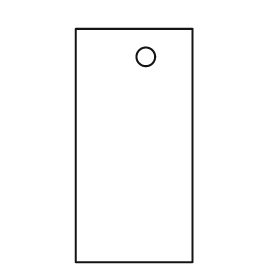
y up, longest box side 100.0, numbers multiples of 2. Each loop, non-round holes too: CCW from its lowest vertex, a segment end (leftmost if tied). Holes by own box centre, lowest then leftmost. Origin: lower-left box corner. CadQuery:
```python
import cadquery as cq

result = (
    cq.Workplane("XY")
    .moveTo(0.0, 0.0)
    .lineTo(50.0, 0.0)
    .lineTo(50.0, 100.0)
    .lineTo(0.0, 100.0)
    .close()
    .moveTo(30.0, 88.0)
    .circle(4.0)
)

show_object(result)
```